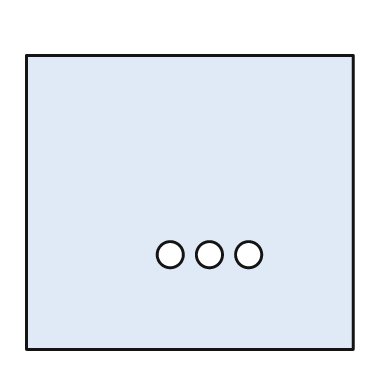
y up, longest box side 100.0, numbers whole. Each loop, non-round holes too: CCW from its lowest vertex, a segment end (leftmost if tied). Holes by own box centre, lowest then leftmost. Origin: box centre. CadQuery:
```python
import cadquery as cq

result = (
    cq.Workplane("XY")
    .moveTo(-50.0, -45.0)
    .lineTo(50.0, -45.0)
    .lineTo(50.0, 45.0)
    .lineTo(-50.0, 45.0)
    .close()
    .moveTo(-6.0, -16.0)
    .circle(4.0)
    .moveTo(6.0, -16.0)
    .circle(4.0)
    .moveTo(18.0, -16.0)
    .circle(4.0)
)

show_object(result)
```